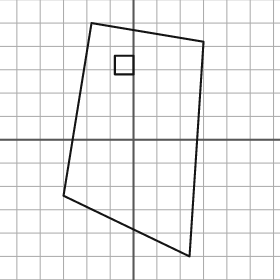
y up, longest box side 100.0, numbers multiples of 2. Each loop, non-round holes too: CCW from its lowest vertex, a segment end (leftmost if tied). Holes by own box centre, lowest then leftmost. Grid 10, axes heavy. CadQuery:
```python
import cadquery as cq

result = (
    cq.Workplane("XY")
    .moveTo(24.0, -50.0)
    .lineTo(30.0, 42.0)
    .lineTo(-18.0, 50.0)
    .lineTo(-30.0, -24.0)
    .close()
    .moveTo(-8.0, 28.0)
    .lineTo(0.0, 28.0)
    .lineTo(0.0, 36.0)
    .lineTo(-8.0, 36.0)
    .close()
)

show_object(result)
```